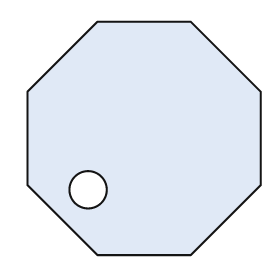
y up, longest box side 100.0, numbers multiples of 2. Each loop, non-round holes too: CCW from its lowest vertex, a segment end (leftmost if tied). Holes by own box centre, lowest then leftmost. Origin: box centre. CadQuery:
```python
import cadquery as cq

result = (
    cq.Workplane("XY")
    .moveTo(-20.0, -50.0)
    .lineTo(20.0, -50.0)
    .lineTo(50.0, -20.0)
    .lineTo(50.0, 20.0)
    .lineTo(20.0, 50.0)
    .lineTo(-20.0, 50.0)
    .lineTo(-50.0, 20.0)
    .lineTo(-50.0, -20.0)
    .close()
    .moveTo(-24.0, -22.0)
    .circle(8.0)
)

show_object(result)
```